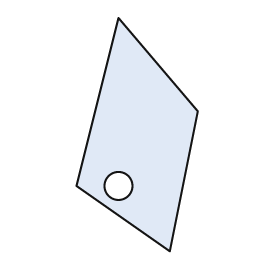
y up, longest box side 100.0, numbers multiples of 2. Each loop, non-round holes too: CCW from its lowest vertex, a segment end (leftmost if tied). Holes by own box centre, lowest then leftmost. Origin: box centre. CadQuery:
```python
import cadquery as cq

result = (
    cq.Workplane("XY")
    .moveTo(14.0, -50.0)
    .lineTo(26.0, 10.0)
    .lineTo(-8.0, 50.0)
    .lineTo(-26.0, -22.0)
    .close()
    .moveTo(-8.0, -22.0)
    .circle(6.0)
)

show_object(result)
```